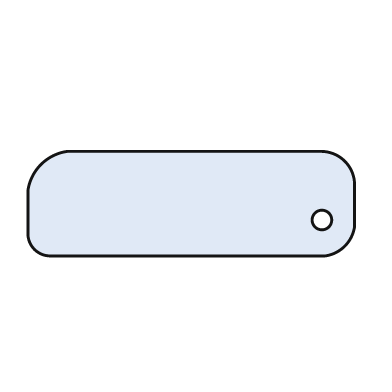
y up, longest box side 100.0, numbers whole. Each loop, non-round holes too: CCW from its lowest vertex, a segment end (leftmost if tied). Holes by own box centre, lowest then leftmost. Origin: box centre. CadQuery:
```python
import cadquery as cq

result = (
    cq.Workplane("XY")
    .moveTo(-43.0, -16.0)
    .lineTo(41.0, -16.0)
    .threePointArc((47.0, -13.0), (50.0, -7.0))
    .lineTo(50.0, 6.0)
    .threePointArc((47.0, 13.0), (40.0, 16.0))
    .lineTo(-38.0, 16.0)
    .threePointArc((-46.0, 12.0), (-50.0, 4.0))
    .lineTo(-50.0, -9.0)
    .threePointArc((-48.0, -14.0), (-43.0, -16.0))
    .close()
    .moveTo(40.0, -5.0)
    .circle(3.0)
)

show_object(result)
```